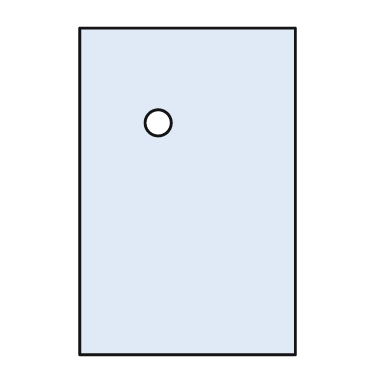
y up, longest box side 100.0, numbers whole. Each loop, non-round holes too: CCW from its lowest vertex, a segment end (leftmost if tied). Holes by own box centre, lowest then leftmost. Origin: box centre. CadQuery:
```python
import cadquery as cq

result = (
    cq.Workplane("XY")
    .moveTo(-33.0, -50.0)
    .lineTo(33.0, -50.0)
    .lineTo(33.0, 50.0)
    .lineTo(-33.0, 50.0)
    .close()
    .moveTo(-9.0, 21.0)
    .circle(4.0)
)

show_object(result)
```